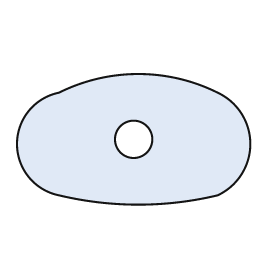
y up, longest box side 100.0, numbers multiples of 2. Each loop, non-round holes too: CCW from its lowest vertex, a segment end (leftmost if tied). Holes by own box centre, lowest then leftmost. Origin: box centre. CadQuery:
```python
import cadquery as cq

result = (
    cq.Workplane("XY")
    .moveTo(-32.0, -24.0)
    .threePointArc((2.0, -28.0), (36.0, -24.0))
    .threePointArc((50.0, -2.0), (36.0, 20.0))
    .threePointArc((2.0, 28.0), (-32.0, 20.0))
    .threePointArc((-50.0, -2.0), (-32.0, -24.0))
    .close()
    .moveTo(0.0, 0.0)
    .circle(8.0)
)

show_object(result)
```